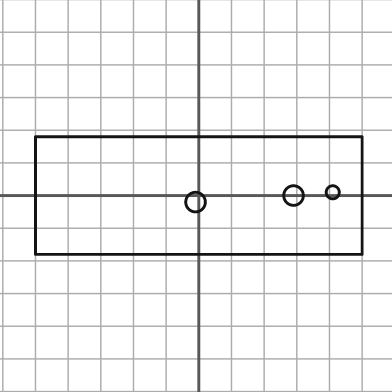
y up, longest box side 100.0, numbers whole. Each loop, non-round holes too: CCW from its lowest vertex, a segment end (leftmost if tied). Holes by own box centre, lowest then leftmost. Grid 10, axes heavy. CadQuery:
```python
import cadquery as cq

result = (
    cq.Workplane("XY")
    .moveTo(-50.0, -18.0)
    .lineTo(50.0, -18.0)
    .lineTo(50.0, 18.0)
    .lineTo(-50.0, 18.0)
    .close()
    .moveTo(-1.0, -2.0)
    .circle(3.0)
    .moveTo(29.0, 0.0)
    .circle(3.0)
    .moveTo(41.0, 1.0)
    .circle(2.0)
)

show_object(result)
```